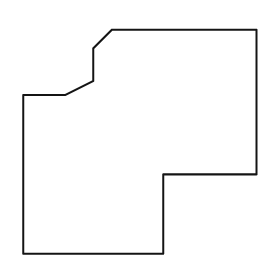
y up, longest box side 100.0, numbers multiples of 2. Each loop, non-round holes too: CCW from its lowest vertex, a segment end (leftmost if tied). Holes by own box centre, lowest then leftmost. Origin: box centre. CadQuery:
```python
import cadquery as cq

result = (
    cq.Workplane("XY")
    .moveTo(-50.0, -48.0)
    .lineTo(10.0, -48.0)
    .lineTo(10.0, -14.0)
    .lineTo(50.0, -14.0)
    .lineTo(50.0, 48.0)
    .lineTo(-12.0, 48.0)
    .lineTo(-20.0, 40.0)
    .lineTo(-20.0, 26.0)
    .lineTo(-32.0, 20.0)
    .lineTo(-50.0, 20.0)
    .close()
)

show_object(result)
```